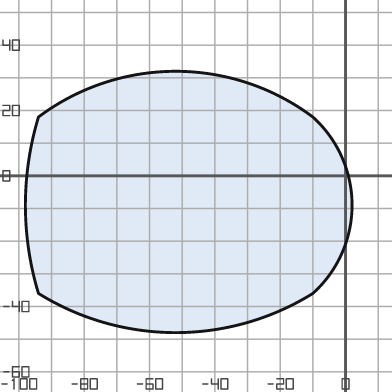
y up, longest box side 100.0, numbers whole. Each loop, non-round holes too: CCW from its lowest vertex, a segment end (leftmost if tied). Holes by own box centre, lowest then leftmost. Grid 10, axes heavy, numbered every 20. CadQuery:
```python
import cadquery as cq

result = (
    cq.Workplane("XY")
    .moveTo(-94.0, -36.0)
    .threePointArc((-52.0, -48.0), (-10.0, -36.0))
    .threePointArc((2.0, -9.0), (-10.0, 18.0))
    .threePointArc((-52.0, 32.0), (-94.0, 18.0))
    .threePointArc((-98.0, -9.0), (-94.0, -36.0))
    .close()
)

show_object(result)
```